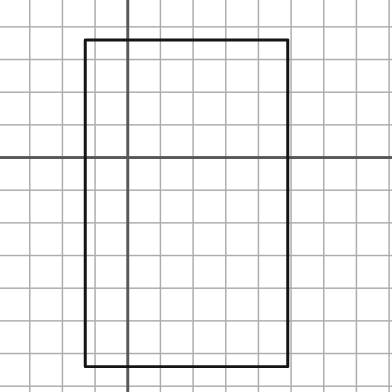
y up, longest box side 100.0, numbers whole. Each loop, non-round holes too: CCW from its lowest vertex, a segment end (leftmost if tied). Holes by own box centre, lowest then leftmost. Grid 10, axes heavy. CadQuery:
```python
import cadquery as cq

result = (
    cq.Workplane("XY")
    .moveTo(-13.0, -64.0)
    .lineTo(49.0, -64.0)
    .lineTo(49.0, 36.0)
    .lineTo(-13.0, 36.0)
    .close()
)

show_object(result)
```